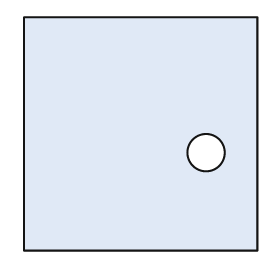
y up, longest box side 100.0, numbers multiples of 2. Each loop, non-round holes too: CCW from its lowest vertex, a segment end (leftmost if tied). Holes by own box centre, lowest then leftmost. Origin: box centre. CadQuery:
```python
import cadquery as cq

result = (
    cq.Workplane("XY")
    .moveTo(-50.0, -50.0)
    .lineTo(50.0, -50.0)
    .lineTo(50.0, 50.0)
    .lineTo(-50.0, 50.0)
    .close()
    .moveTo(28.0, -8.0)
    .circle(8.0)
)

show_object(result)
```